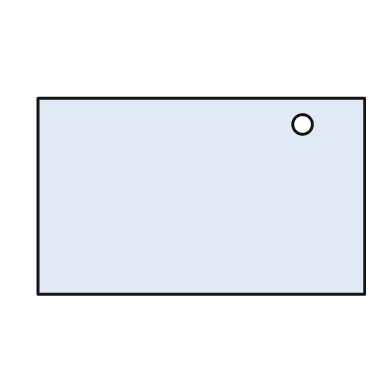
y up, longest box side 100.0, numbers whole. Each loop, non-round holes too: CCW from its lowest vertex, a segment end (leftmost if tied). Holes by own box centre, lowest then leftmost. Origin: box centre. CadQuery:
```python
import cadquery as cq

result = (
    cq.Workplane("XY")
    .moveTo(-50.0, -30.0)
    .lineTo(50.0, -30.0)
    .lineTo(50.0, 30.0)
    .lineTo(-50.0, 30.0)
    .close()
    .moveTo(31.0, 22.0)
    .circle(3.0)
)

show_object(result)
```